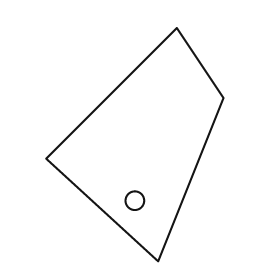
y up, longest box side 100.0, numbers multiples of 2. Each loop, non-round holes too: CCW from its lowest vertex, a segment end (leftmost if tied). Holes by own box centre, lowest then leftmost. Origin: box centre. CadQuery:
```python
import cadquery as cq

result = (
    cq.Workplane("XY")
    .moveTo(10.0, -50.0)
    .lineTo(38.0, 20.0)
    .lineTo(18.0, 50.0)
    .lineTo(-38.0, -6.0)
    .close()
    .moveTo(0.0, -24.0)
    .circle(4.0)
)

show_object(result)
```